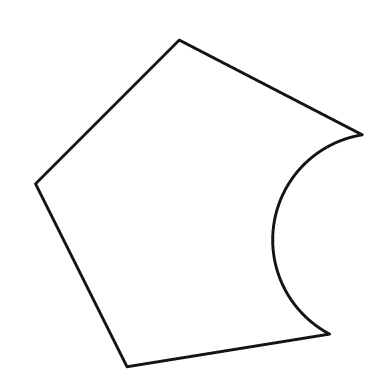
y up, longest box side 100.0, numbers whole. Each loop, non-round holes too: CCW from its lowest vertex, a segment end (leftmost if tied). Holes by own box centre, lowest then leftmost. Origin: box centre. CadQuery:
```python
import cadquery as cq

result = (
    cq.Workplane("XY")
    .moveTo(-22.0, -50.0)
    .lineTo(40.0, -40.0)
    .threePointArc((23.0, -6.0), (50.0, 21.0))
    .lineTo(-6.0, 50.0)
    .lineTo(-50.0, 6.0)
    .close()
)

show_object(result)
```